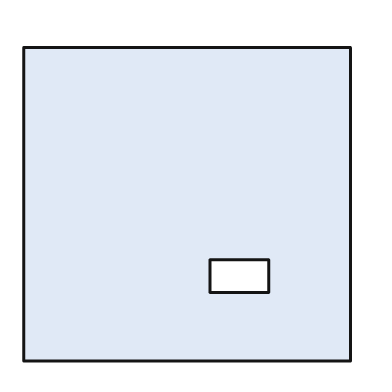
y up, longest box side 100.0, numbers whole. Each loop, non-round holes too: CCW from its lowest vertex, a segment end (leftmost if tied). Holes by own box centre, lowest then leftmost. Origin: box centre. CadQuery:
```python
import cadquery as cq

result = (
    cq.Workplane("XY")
    .moveTo(-50.0, -48.0)
    .lineTo(50.0, -48.0)
    .lineTo(50.0, 48.0)
    .lineTo(-50.0, 48.0)
    .close()
    .moveTo(7.0, -27.0)
    .lineTo(25.0, -27.0)
    .lineTo(25.0, -17.0)
    .lineTo(7.0, -17.0)
    .close()
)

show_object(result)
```